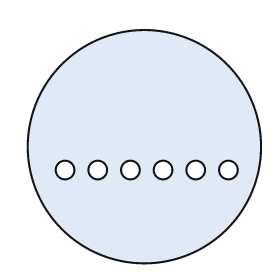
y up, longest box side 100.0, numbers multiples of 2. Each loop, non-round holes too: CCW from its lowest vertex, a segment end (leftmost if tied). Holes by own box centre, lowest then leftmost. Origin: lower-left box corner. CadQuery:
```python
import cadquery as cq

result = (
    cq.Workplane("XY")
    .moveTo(50.0, 50.0)
    .circle(50.0)
    .moveTo(16.0, 40.0)
    .circle(4.0)
    .moveTo(30.0, 40.0)
    .circle(4.0)
    .moveTo(44.0, 40.0)
    .circle(4.0)
    .moveTo(58.0, 40.0)
    .circle(4.0)
    .moveTo(72.0, 40.0)
    .circle(4.0)
    .moveTo(86.0, 40.0)
    .circle(4.0)
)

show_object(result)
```